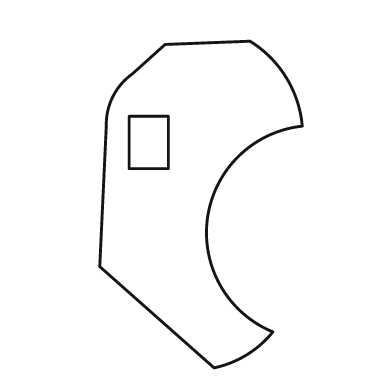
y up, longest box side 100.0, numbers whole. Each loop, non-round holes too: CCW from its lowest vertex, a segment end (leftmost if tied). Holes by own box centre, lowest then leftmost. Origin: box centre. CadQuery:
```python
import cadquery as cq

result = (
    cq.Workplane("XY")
    .moveTo(4.0, -50.0)
    .threePointArc((14.0, -46.0), (22.0, -39.0))
    .threePointArc((2.0, -4.0), (31.0, 24.0))
    .threePointArc((26.0, 39.0), (15.0, 50.0))
    .lineTo(-11.0, 49.0)
    .lineTo(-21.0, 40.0)
    .threePointArc((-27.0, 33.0), (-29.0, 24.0))
    .lineTo(-31.0, -19.0)
    .close()
    .moveTo(-22.0, 11.0)
    .lineTo(-10.0, 11.0)
    .lineTo(-10.0, 27.0)
    .lineTo(-22.0, 27.0)
    .close()
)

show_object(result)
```